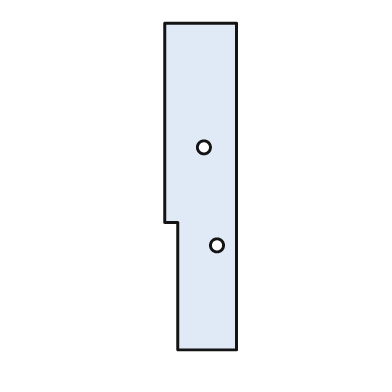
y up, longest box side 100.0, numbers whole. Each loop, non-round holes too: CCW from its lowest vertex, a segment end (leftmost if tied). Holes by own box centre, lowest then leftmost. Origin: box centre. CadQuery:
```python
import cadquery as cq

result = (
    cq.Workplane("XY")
    .moveTo(-7.0, -50.0)
    .lineTo(11.0, -50.0)
    .lineTo(11.0, 50.0)
    .lineTo(-11.0, 50.0)
    .lineTo(-11.0, -11.0)
    .lineTo(-7.0, -11.0)
    .close()
    .moveTo(5.0, -18.0)
    .circle(2.0)
    .moveTo(1.0, 12.0)
    .circle(2.0)
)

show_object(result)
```